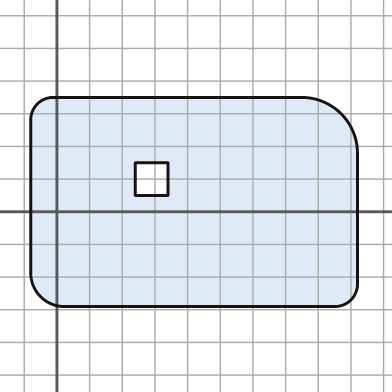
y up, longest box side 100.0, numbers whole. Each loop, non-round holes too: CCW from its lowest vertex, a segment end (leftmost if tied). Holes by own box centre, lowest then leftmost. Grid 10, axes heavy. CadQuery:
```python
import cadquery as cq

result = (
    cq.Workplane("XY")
    .moveTo(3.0, -29.0)
    .lineTo(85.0, -29.0)
    .threePointArc((90.0, -27.0), (92.0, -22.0))
    .lineTo(92.0, 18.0)
    .threePointArc((87.0, 30.0), (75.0, 35.0))
    .lineTo(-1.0, 35.0)
    .threePointArc((-6.0, 33.0), (-8.0, 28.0))
    .lineTo(-8.0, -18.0)
    .threePointArc((-5.0, -26.0), (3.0, -29.0))
    .close()
    .moveTo(24.0, 5.0)
    .lineTo(34.0, 5.0)
    .lineTo(34.0, 15.0)
    .lineTo(24.0, 15.0)
    .close()
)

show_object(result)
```